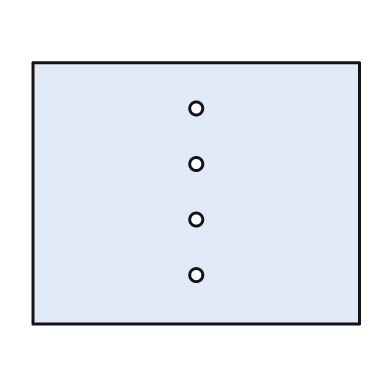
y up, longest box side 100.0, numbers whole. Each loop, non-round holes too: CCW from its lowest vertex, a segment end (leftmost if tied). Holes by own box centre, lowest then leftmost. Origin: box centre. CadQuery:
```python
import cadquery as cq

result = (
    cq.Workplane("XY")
    .moveTo(-50.0, -40.0)
    .lineTo(50.0, -40.0)
    .lineTo(50.0, 40.0)
    .lineTo(-50.0, 40.0)
    .close()
    .moveTo(0.0, -25.0)
    .circle(2.0)
    .moveTo(0.0, -8.0)
    .circle(2.0)
    .moveTo(0.0, 9.0)
    .circle(2.0)
    .moveTo(0.0, 26.0)
    .circle(2.0)
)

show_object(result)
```